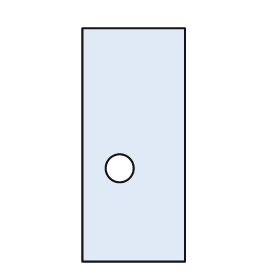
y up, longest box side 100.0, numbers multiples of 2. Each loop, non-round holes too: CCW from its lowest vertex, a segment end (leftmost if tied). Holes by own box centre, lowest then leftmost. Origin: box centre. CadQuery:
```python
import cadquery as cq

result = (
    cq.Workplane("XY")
    .moveTo(-22.0, -50.0)
    .lineTo(22.0, -50.0)
    .lineTo(22.0, 50.0)
    .lineTo(-22.0, 50.0)
    .close()
    .moveTo(-6.0, -10.0)
    .circle(6.0)
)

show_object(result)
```